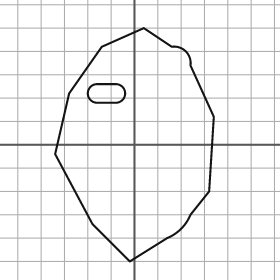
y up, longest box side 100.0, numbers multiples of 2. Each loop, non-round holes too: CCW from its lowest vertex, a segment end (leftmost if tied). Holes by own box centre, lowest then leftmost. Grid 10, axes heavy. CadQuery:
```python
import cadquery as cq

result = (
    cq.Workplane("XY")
    .moveTo(-2.0, -50.0)
    .lineTo(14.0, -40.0)
    .threePointArc((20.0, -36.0), (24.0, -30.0))
    .lineTo(32.0, -20.0)
    .lineTo(34.0, 12.0)
    .lineTo(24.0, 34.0)
    .threePointArc((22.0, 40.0), (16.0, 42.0))
    .lineTo(4.0, 50.0)
    .lineTo(-14.0, 42.0)
    .lineTo(-28.0, 22.0)
    .lineTo(-34.0, -4.0)
    .lineTo(-18.0, -34.0)
    .close()
    .moveTo(-16.0, 18.0)
    .lineTo(-8.0, 18.0)
    .threePointArc((-4.0, 22.0), (-8.0, 26.0))
    .lineTo(-16.0, 26.0)
    .threePointArc((-20.0, 22.0), (-16.0, 18.0))
    .close()
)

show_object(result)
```